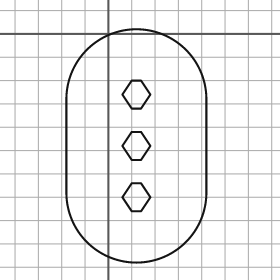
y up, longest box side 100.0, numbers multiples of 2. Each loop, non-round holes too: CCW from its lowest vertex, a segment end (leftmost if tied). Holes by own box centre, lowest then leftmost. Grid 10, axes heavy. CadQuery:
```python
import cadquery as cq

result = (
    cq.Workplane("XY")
    .moveTo(-18.0, -68.0)
    .threePointArc((12.0, -98.0), (42.0, -68.0))
    .lineTo(42.0, -28.0)
    .threePointArc((12.0, 2.0), (-18.0, -28.0))
    .close()
    .moveTo(10.0, -76.0)
    .lineTo(14.0, -76.0)
    .lineTo(18.0, -70.0)
    .lineTo(14.0, -64.0)
    .lineTo(10.0, -64.0)
    .lineTo(6.0, -70.0)
    .close()
    .moveTo(10.0, -54.0)
    .lineTo(14.0, -54.0)
    .lineTo(18.0, -48.0)
    .lineTo(14.0, -42.0)
    .lineTo(10.0, -42.0)
    .lineTo(6.0, -48.0)
    .close()
    .moveTo(10.0, -32.0)
    .lineTo(14.0, -32.0)
    .lineTo(18.0, -26.0)
    .lineTo(14.0, -20.0)
    .lineTo(10.0, -20.0)
    .lineTo(6.0, -26.0)
    .close()
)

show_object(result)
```